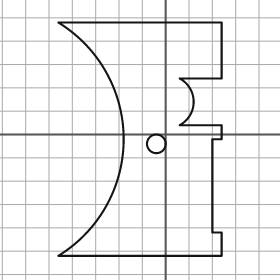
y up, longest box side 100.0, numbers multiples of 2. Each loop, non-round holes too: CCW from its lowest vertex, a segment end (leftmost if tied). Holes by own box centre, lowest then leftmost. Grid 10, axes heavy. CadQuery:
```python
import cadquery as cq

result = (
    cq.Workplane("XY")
    .moveTo(-46.0, -52.0)
    .lineTo(24.0, -52.0)
    .lineTo(24.0, -42.0)
    .lineTo(20.0, -42.0)
    .lineTo(20.0, -2.0)
    .lineTo(24.0, -2.0)
    .lineTo(24.0, 4.0)
    .lineTo(6.0, 4.0)
    .threePointArc((12.0, 14.0), (6.0, 24.0))
    .lineTo(24.0, 24.0)
    .lineTo(24.0, 48.0)
    .lineTo(-46.0, 48.0)
    .threePointArc((-18.0, -2.0), (-46.0, -52.0))
    .close()
    .moveTo(-4.0, -4.0)
    .circle(4.0)
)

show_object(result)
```